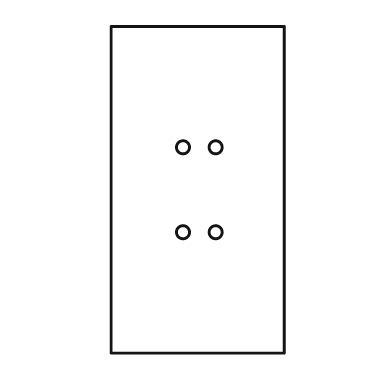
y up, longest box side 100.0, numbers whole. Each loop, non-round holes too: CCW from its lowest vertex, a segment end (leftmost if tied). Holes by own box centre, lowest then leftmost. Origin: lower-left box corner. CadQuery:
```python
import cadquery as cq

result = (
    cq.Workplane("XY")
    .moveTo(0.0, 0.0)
    .lineTo(53.0, 0.0)
    .lineTo(53.0, 100.0)
    .lineTo(0.0, 100.0)
    .close()
    .moveTo(22.0, 37.0)
    .circle(2.0)
    .moveTo(32.0, 37.0)
    .circle(2.0)
    .moveTo(22.0, 63.0)
    .circle(2.0)
    .moveTo(32.0, 63.0)
    .circle(2.0)
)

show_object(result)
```